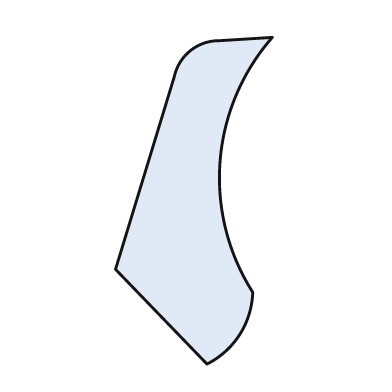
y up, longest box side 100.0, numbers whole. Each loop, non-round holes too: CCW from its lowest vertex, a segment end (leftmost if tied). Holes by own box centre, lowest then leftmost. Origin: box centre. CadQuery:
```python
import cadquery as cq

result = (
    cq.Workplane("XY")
    .moveTo(4.0, -50.0)
    .threePointArc((14.0, -41.0), (18.0, -28.0))
    .threePointArc((8.0, 12.0), (24.0, 50.0))
    .lineTo(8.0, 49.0)
    .threePointArc((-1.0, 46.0), (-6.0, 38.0))
    .lineTo(-24.0, -21.0)
    .close()
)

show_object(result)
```